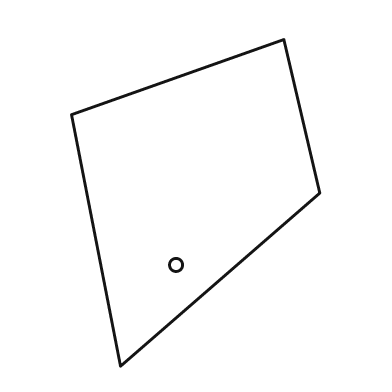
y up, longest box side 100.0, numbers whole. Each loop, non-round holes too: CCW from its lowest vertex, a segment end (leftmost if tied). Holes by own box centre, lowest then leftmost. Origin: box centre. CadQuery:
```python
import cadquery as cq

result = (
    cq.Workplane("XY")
    .moveTo(-23.0, -50.0)
    .lineTo(38.0, 3.0)
    .lineTo(27.0, 50.0)
    .lineTo(-38.0, 27.0)
    .close()
    .moveTo(-6.0, -19.0)
    .circle(2.0)
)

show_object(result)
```